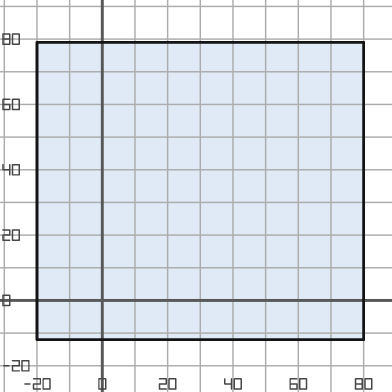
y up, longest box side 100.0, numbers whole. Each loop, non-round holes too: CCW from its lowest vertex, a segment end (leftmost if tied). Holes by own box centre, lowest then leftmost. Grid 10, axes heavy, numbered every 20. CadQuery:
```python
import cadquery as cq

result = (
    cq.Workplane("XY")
    .moveTo(-20.0, -12.0)
    .lineTo(80.0, -12.0)
    .lineTo(80.0, 79.0)
    .lineTo(-20.0, 79.0)
    .close()
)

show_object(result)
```